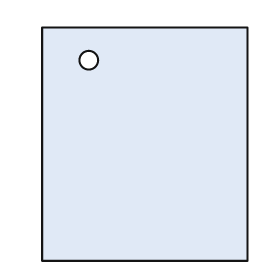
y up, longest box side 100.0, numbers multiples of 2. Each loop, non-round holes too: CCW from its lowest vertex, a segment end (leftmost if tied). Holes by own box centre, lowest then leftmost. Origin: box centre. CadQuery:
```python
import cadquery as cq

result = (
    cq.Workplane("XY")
    .moveTo(-44.0, -50.0)
    .lineTo(44.0, -50.0)
    .lineTo(44.0, 50.0)
    .lineTo(-44.0, 50.0)
    .close()
    .moveTo(-24.0, 36.0)
    .circle(4.0)
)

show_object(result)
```